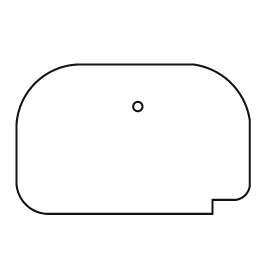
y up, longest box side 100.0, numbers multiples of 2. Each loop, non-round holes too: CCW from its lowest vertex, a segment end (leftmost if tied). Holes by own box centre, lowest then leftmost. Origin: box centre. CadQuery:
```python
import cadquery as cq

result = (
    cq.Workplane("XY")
    .moveTo(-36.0, -32.0)
    .lineTo(34.0, -32.0)
    .lineTo(34.0, -26.0)
    .lineTo(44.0, -26.0)
    .threePointArc((48.0, -24.0), (50.0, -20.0))
    .lineTo(50.0, 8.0)
    .threePointArc((42.0, 24.0), (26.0, 32.0))
    .lineTo(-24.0, 32.0)
    .threePointArc((-42.0, 24.0), (-50.0, 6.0))
    .lineTo(-50.0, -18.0)
    .threePointArc((-46.0, -28.0), (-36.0, -32.0))
    .close()
    .moveTo(2.0, 14.0)
    .circle(2.0)
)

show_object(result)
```